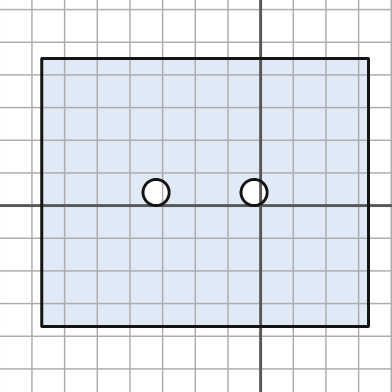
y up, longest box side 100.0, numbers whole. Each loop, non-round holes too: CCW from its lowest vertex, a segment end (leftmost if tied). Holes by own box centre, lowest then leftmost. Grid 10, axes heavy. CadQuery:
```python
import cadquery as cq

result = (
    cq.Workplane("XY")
    .moveTo(-67.0, -37.0)
    .lineTo(33.0, -37.0)
    .lineTo(33.0, 45.0)
    .lineTo(-67.0, 45.0)
    .close()
    .moveTo(-32.0, 4.0)
    .circle(4.0)
    .moveTo(-2.0, 4.0)
    .circle(4.0)
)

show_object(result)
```